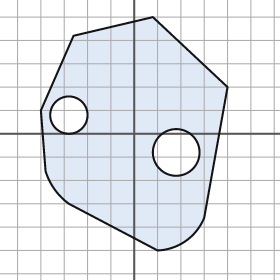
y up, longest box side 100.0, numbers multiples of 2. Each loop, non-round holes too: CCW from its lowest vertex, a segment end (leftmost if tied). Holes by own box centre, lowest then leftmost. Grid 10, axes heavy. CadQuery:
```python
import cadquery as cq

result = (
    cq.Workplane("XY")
    .moveTo(10.0, -50.0)
    .threePointArc((22.0, -46.0), (30.0, -36.0))
    .lineTo(40.0, 20.0)
    .lineTo(8.0, 50.0)
    .lineTo(-26.0, 42.0)
    .lineTo(-40.0, 10.0)
    .lineTo(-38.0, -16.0)
    .threePointArc((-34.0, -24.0), (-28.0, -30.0))
    .close()
    .moveTo(18.0, -8.0)
    .circle(10.0)
    .moveTo(-28.0, 8.0)
    .circle(8.0)
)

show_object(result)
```